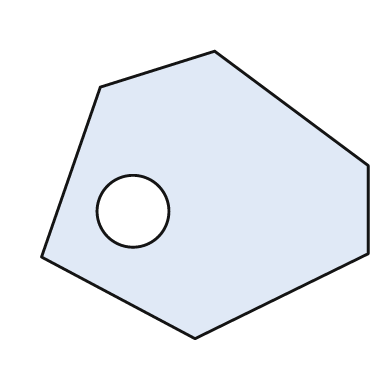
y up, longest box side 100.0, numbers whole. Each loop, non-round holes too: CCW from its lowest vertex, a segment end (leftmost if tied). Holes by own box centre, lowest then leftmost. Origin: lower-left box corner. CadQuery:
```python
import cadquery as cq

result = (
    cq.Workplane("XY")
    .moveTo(47.0, 0.0)
    .lineTo(100.0, 26.0)
    .lineTo(100.0, 53.0)
    .lineTo(53.0, 88.0)
    .lineTo(18.0, 77.0)
    .lineTo(0.0, 25.0)
    .close()
    .moveTo(28.0, 39.0)
    .circle(11.0)
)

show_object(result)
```